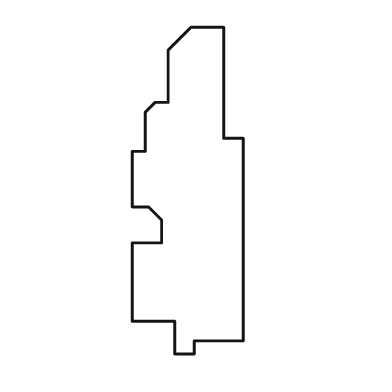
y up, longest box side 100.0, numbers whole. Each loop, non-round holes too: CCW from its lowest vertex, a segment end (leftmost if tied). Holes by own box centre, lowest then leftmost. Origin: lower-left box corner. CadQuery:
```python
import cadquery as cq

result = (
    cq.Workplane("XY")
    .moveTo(13.0, 0.0)
    .lineTo(19.0, 0.0)
    .lineTo(19.0, 4.0)
    .lineTo(34.0, 4.0)
    .lineTo(34.0, 66.0)
    .lineTo(28.0, 66.0)
    .lineTo(28.0, 100.0)
    .lineTo(18.0, 100.0)
    .lineTo(11.0, 93.0)
    .lineTo(11.0, 77.0)
    .lineTo(7.0, 77.0)
    .lineTo(4.0, 74.0)
    .lineTo(4.0, 62.0)
    .lineTo(0.0, 62.0)
    .lineTo(0.0, 45.0)
    .lineTo(5.0, 45.0)
    .lineTo(9.0, 41.0)
    .lineTo(9.0, 34.0)
    .lineTo(0.0, 34.0)
    .lineTo(0.0, 10.0)
    .lineTo(13.0, 10.0)
    .close()
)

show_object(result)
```